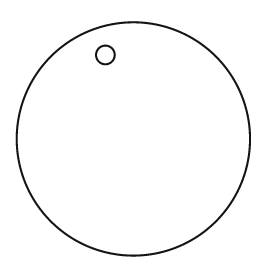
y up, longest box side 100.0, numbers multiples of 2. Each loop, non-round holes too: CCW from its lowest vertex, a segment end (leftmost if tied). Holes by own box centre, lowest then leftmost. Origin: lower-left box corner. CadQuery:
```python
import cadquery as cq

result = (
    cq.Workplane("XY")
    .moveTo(50.0, 50.0)
    .circle(50.0)
    .moveTo(38.0, 86.0)
    .circle(4.0)
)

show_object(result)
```